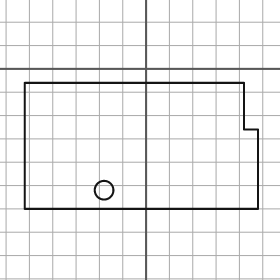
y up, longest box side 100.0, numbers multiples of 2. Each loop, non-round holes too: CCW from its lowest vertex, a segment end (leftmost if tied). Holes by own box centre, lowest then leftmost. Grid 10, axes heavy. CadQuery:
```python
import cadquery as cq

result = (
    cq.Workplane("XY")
    .moveTo(-52.0, -60.0)
    .lineTo(48.0, -60.0)
    .lineTo(48.0, -26.0)
    .lineTo(42.0, -26.0)
    .lineTo(42.0, -6.0)
    .lineTo(-52.0, -6.0)
    .close()
    .moveTo(-18.0, -52.0)
    .circle(4.0)
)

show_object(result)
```